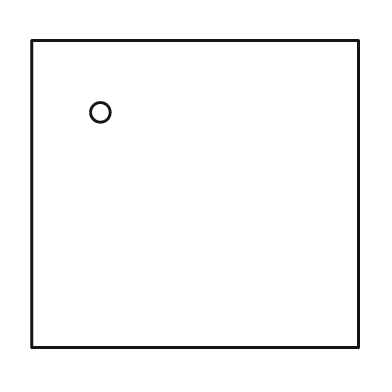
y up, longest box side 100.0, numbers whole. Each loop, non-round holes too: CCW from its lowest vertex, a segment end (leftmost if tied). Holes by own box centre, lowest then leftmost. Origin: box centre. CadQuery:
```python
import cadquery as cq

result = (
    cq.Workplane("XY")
    .moveTo(-50.0, -47.0)
    .lineTo(50.0, -47.0)
    .lineTo(50.0, 47.0)
    .lineTo(-50.0, 47.0)
    .close()
    .moveTo(-29.0, 25.0)
    .circle(3.0)
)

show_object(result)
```